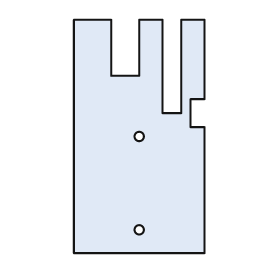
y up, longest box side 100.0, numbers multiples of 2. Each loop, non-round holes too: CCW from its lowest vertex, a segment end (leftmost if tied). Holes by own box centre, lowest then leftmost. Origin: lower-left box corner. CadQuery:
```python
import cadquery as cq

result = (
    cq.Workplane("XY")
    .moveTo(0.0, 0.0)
    .lineTo(56.0, 0.0)
    .lineTo(56.0, 54.0)
    .lineTo(50.0, 54.0)
    .lineTo(50.0, 66.0)
    .lineTo(56.0, 66.0)
    .lineTo(56.0, 100.0)
    .lineTo(46.0, 100.0)
    .lineTo(46.0, 60.0)
    .lineTo(38.0, 60.0)
    .lineTo(38.0, 100.0)
    .lineTo(28.0, 100.0)
    .lineTo(28.0, 76.0)
    .lineTo(16.0, 76.0)
    .lineTo(16.0, 100.0)
    .lineTo(0.0, 100.0)
    .close()
    .moveTo(28.0, 10.0)
    .circle(2.0)
    .moveTo(28.0, 50.0)
    .circle(2.0)
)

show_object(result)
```